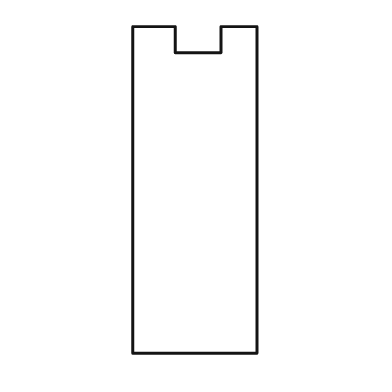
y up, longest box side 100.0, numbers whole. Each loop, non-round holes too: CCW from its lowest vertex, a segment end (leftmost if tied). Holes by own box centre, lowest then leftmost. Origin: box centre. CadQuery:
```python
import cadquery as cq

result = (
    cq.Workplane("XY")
    .moveTo(-19.0, -50.0)
    .lineTo(19.0, -50.0)
    .lineTo(19.0, 50.0)
    .lineTo(8.0, 50.0)
    .lineTo(8.0, 42.0)
    .lineTo(-6.0, 42.0)
    .lineTo(-6.0, 50.0)
    .lineTo(-19.0, 50.0)
    .close()
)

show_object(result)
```